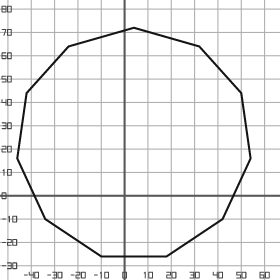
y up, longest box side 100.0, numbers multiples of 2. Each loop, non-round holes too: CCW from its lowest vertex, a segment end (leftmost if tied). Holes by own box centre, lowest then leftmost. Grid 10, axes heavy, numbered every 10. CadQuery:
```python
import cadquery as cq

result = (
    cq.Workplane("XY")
    .moveTo(-10.0, -26.0)
    .lineTo(18.0, -26.0)
    .lineTo(42.0, -10.0)
    .lineTo(54.0, 16.0)
    .lineTo(50.0, 44.0)
    .lineTo(32.0, 64.0)
    .lineTo(4.0, 72.0)
    .lineTo(-24.0, 64.0)
    .lineTo(-42.0, 44.0)
    .lineTo(-46.0, 16.0)
    .lineTo(-34.0, -10.0)
    .close()
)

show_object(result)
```